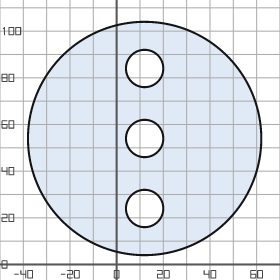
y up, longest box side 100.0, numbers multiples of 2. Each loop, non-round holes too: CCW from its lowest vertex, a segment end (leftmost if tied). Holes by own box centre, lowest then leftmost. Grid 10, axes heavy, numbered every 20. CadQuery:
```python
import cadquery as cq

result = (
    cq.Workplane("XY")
    .moveTo(12.0, 54.0)
    .circle(50.0)
    .moveTo(12.0, 24.0)
    .circle(8.0)
    .moveTo(12.0, 54.0)
    .circle(8.0)
    .moveTo(12.0, 84.0)
    .circle(8.0)
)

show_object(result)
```